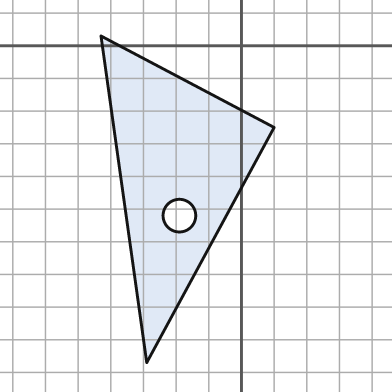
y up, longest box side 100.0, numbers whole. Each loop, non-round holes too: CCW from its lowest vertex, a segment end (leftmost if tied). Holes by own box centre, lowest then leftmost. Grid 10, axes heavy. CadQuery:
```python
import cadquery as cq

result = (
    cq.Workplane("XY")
    .moveTo(-29.0, -97.0)
    .lineTo(10.0, -25.0)
    .lineTo(-43.0, 3.0)
    .close()
    .moveTo(-19.0, -52.0)
    .circle(5.0)
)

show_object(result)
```